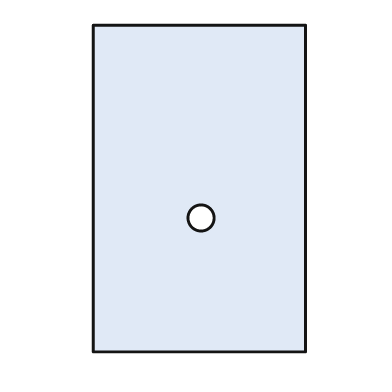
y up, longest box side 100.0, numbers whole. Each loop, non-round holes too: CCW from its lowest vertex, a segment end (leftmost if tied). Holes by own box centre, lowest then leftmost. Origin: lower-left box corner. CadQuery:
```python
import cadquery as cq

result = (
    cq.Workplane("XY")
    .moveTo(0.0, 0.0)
    .lineTo(65.0, 0.0)
    .lineTo(65.0, 100.0)
    .lineTo(0.0, 100.0)
    .close()
    .moveTo(33.0, 41.0)
    .circle(4.0)
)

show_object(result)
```